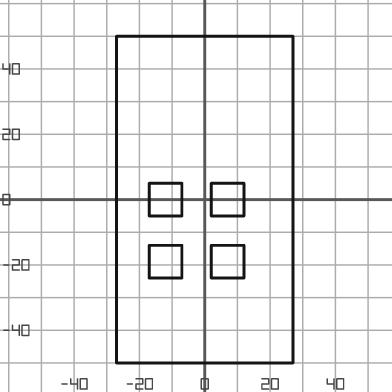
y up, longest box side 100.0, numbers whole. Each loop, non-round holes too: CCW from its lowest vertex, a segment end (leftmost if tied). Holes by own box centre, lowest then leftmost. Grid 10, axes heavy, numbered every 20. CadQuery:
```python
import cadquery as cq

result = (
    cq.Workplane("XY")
    .moveTo(-27.0, -50.0)
    .lineTo(27.0, -50.0)
    .lineTo(27.0, 50.0)
    .lineTo(-27.0, 50.0)
    .close()
    .moveTo(-17.0, -24.0)
    .lineTo(-7.0, -24.0)
    .lineTo(-7.0, -14.0)
    .lineTo(-17.0, -14.0)
    .close()
    .moveTo(2.0, -24.0)
    .lineTo(12.0, -24.0)
    .lineTo(12.0, -14.0)
    .lineTo(2.0, -14.0)
    .close()
    .moveTo(-17.0, -5.0)
    .lineTo(-7.0, -5.0)
    .lineTo(-7.0, 5.0)
    .lineTo(-17.0, 5.0)
    .close()
    .moveTo(2.0, -5.0)
    .lineTo(12.0, -5.0)
    .lineTo(12.0, 5.0)
    .lineTo(2.0, 5.0)
    .close()
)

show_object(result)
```